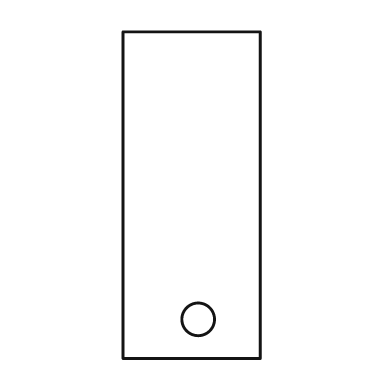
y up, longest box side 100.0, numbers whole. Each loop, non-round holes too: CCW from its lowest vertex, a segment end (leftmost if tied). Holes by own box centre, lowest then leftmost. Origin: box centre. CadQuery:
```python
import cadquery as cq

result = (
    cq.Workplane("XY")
    .moveTo(-21.0, -50.0)
    .lineTo(21.0, -50.0)
    .lineTo(21.0, 50.0)
    .lineTo(-21.0, 50.0)
    .close()
    .moveTo(2.0, -38.0)
    .circle(5.0)
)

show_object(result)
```